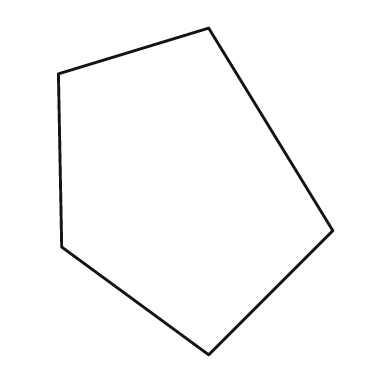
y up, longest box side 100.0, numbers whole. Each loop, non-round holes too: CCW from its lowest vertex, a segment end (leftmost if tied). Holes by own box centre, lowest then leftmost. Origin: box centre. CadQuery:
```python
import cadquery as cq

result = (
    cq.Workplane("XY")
    .moveTo(4.0, -50.0)
    .lineTo(42.0, -12.0)
    .lineTo(4.0, 50.0)
    .lineTo(-42.0, 36.0)
    .lineTo(-41.0, -17.0)
    .close()
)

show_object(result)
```